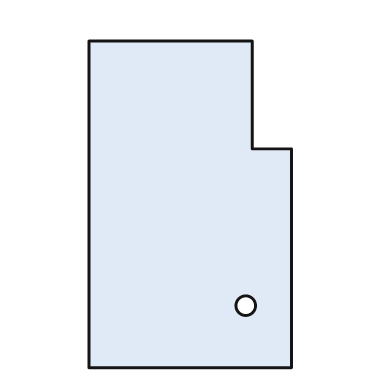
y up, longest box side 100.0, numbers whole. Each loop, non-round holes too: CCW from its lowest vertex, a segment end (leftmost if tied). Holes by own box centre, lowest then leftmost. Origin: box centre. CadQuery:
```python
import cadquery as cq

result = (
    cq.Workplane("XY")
    .moveTo(-31.0, -50.0)
    .lineTo(31.0, -50.0)
    .lineTo(31.0, 17.0)
    .lineTo(19.0, 17.0)
    .lineTo(19.0, 50.0)
    .lineTo(-31.0, 50.0)
    .close()
    .moveTo(17.0, -31.0)
    .circle(3.0)
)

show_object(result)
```